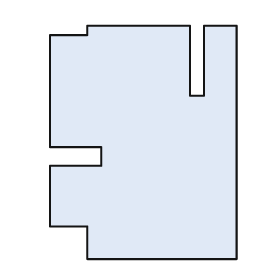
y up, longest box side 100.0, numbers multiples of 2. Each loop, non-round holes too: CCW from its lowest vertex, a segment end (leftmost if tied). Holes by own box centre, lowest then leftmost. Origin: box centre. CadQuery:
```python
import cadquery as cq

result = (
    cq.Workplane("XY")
    .moveTo(-24.0, -50.0)
    .lineTo(40.0, -50.0)
    .lineTo(40.0, 50.0)
    .lineTo(26.0, 50.0)
    .lineTo(26.0, 20.0)
    .lineTo(20.0, 20.0)
    .lineTo(20.0, 50.0)
    .lineTo(-24.0, 50.0)
    .lineTo(-24.0, 46.0)
    .lineTo(-40.0, 46.0)
    .lineTo(-40.0, -2.0)
    .lineTo(-18.0, -2.0)
    .lineTo(-18.0, -10.0)
    .lineTo(-40.0, -10.0)
    .lineTo(-40.0, -36.0)
    .lineTo(-24.0, -36.0)
    .close()
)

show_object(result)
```